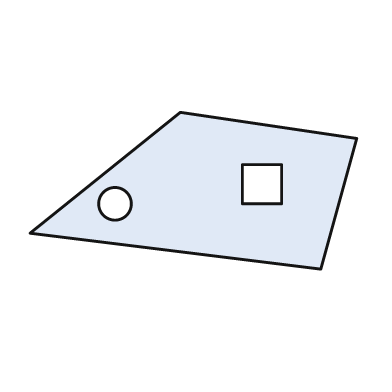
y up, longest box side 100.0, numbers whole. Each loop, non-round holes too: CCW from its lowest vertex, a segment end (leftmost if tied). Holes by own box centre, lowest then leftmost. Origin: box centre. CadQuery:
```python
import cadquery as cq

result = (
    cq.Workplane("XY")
    .moveTo(39.0, -24.0)
    .lineTo(50.0, 16.0)
    .lineTo(-4.0, 24.0)
    .lineTo(-50.0, -13.0)
    .close()
    .moveTo(-24.0, -4.0)
    .circle(5.0)
    .moveTo(15.0, -4.0)
    .lineTo(27.0, -4.0)
    .lineTo(27.0, 8.0)
    .lineTo(15.0, 8.0)
    .close()
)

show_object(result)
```